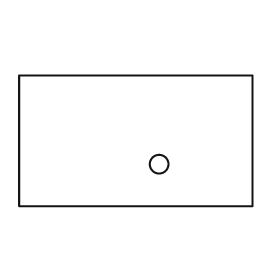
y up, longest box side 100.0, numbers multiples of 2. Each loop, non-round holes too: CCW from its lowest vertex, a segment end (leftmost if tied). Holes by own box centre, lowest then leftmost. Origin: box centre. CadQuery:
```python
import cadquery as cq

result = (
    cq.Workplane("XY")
    .moveTo(-50.0, -28.0)
    .lineTo(50.0, -28.0)
    .lineTo(50.0, 28.0)
    .lineTo(-50.0, 28.0)
    .close()
    .moveTo(10.0, -10.0)
    .circle(4.0)
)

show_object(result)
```